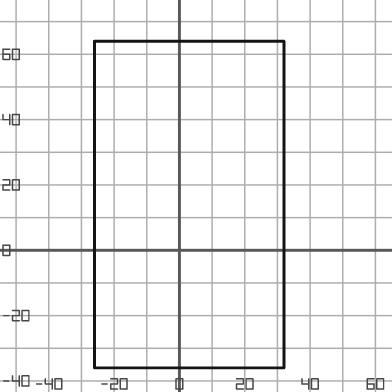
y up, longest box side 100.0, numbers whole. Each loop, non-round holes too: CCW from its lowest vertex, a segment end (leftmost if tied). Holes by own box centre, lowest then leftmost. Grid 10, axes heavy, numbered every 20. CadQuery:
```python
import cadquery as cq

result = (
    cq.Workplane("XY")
    .moveTo(-26.0, -36.0)
    .lineTo(32.0, -36.0)
    .lineTo(32.0, 64.0)
    .lineTo(-26.0, 64.0)
    .close()
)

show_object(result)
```